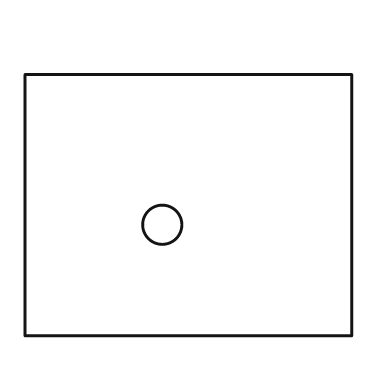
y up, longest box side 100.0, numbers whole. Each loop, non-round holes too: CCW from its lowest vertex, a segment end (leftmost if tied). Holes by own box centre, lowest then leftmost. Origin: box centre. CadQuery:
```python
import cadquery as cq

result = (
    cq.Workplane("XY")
    .moveTo(-50.0, -40.0)
    .lineTo(50.0, -40.0)
    .lineTo(50.0, 40.0)
    .lineTo(-50.0, 40.0)
    .close()
    .moveTo(-8.0, -6.0)
    .circle(6.0)
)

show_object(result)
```